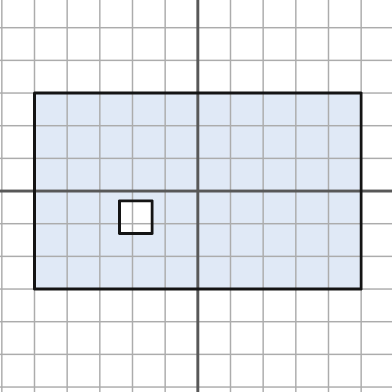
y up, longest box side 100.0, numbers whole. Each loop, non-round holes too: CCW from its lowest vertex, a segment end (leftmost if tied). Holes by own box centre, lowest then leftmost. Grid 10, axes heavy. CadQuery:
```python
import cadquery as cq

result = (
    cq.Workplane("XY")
    .moveTo(-50.0, -30.0)
    .lineTo(50.0, -30.0)
    .lineTo(50.0, 30.0)
    .lineTo(-50.0, 30.0)
    .close()
    .moveTo(-24.0, -13.0)
    .lineTo(-14.0, -13.0)
    .lineTo(-14.0, -3.0)
    .lineTo(-24.0, -3.0)
    .close()
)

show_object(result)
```